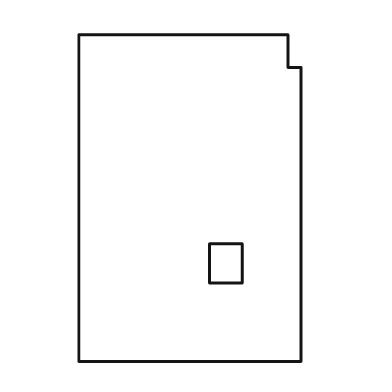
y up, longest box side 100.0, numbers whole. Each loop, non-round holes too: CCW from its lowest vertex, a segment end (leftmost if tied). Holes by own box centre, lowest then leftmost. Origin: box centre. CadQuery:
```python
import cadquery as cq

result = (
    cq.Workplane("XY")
    .moveTo(-34.0, -50.0)
    .lineTo(34.0, -50.0)
    .lineTo(34.0, 40.0)
    .lineTo(30.0, 40.0)
    .lineTo(30.0, 50.0)
    .lineTo(-34.0, 50.0)
    .close()
    .moveTo(6.0, -26.0)
    .lineTo(16.0, -26.0)
    .lineTo(16.0, -14.0)
    .lineTo(6.0, -14.0)
    .close()
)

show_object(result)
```